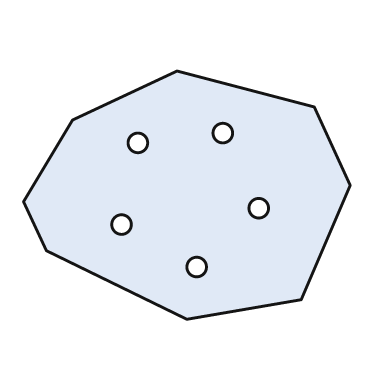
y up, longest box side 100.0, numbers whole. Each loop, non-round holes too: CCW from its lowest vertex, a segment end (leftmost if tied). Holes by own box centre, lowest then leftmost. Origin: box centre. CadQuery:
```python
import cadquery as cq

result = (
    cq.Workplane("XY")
    .moveTo(0.0, -38.0)
    .lineTo(35.0, -32.0)
    .lineTo(50.0, 3.0)
    .lineTo(39.0, 27.0)
    .lineTo(-3.0, 38.0)
    .lineTo(-35.0, 23.0)
    .lineTo(-50.0, -2.0)
    .lineTo(-43.0, -17.0)
    .close()
    .moveTo(3.0, -22.0)
    .circle(3.0)
    .moveTo(-20.0, -9.0)
    .circle(3.0)
    .moveTo(22.0, -4.0)
    .circle(3.0)
    .moveTo(-15.0, 16.0)
    .circle(3.0)
    .moveTo(11.0, 19.0)
    .circle(3.0)
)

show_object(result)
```